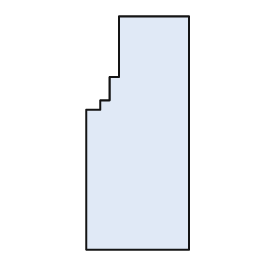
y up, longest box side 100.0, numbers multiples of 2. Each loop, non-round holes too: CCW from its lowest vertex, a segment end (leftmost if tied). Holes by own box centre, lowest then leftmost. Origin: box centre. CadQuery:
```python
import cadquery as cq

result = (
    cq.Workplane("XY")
    .moveTo(-22.0, -50.0)
    .lineTo(22.0, -50.0)
    .lineTo(22.0, 50.0)
    .lineTo(-8.0, 50.0)
    .lineTo(-8.0, 24.0)
    .lineTo(-12.0, 24.0)
    .lineTo(-12.0, 14.0)
    .lineTo(-16.0, 14.0)
    .lineTo(-16.0, 10.0)
    .lineTo(-22.0, 10.0)
    .close()
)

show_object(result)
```